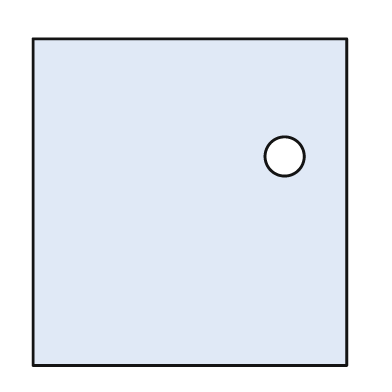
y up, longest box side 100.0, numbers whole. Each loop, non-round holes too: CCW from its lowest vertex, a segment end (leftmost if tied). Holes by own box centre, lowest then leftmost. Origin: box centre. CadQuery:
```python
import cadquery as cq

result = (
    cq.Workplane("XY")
    .moveTo(-48.0, -50.0)
    .lineTo(48.0, -50.0)
    .lineTo(48.0, 50.0)
    .lineTo(-48.0, 50.0)
    .close()
    .moveTo(29.0, 14.0)
    .circle(6.0)
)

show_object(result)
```